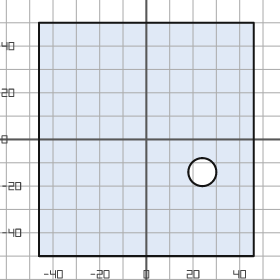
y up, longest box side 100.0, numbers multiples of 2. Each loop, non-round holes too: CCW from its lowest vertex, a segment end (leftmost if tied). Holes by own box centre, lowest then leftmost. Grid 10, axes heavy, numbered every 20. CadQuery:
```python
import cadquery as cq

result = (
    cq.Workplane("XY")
    .moveTo(-46.0, -50.0)
    .lineTo(46.0, -50.0)
    .lineTo(46.0, 50.0)
    .lineTo(-46.0, 50.0)
    .close()
    .moveTo(24.0, -14.0)
    .circle(6.0)
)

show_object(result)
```